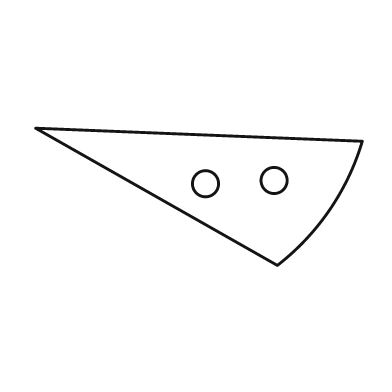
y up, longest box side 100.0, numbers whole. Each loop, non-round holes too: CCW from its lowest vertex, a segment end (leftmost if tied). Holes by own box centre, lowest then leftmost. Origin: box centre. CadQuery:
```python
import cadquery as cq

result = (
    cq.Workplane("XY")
    .moveTo(24.0, -21.0)
    .threePointArc((40.0, -4.0), (50.0, 17.0))
    .lineTo(-50.0, 21.0)
    .close()
    .moveTo(2.0, 4.0)
    .circle(4.0)
    .moveTo(23.0, 5.0)
    .circle(4.0)
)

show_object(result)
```